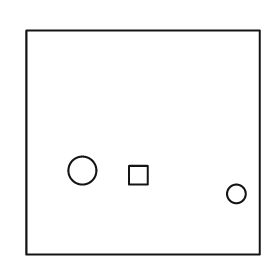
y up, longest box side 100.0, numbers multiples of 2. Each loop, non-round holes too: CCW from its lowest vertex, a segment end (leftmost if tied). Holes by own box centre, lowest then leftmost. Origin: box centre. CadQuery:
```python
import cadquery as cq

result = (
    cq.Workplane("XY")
    .moveTo(-50.0, -48.0)
    .lineTo(50.0, -48.0)
    .lineTo(50.0, 48.0)
    .lineTo(-50.0, 48.0)
    .close()
    .moveTo(40.0, -22.0)
    .circle(4.0)
    .moveTo(-6.0, -18.0)
    .lineTo(2.0, -18.0)
    .lineTo(2.0, -10.0)
    .lineTo(-6.0, -10.0)
    .close()
    .moveTo(-26.0, -12.0)
    .circle(6.0)
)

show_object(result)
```